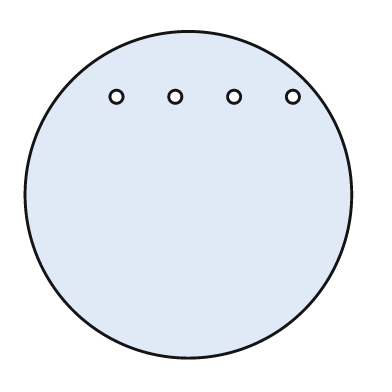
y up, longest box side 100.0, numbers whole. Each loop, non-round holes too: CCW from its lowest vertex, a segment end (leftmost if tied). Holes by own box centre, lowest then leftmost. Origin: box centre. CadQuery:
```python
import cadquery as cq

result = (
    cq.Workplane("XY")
    .moveTo(0.0, 0.0)
    .circle(50.0)
    .moveTo(-22.0, 30.0)
    .circle(2.0)
    .moveTo(-4.0, 30.0)
    .circle(2.0)
    .moveTo(14.0, 30.0)
    .circle(2.0)
    .moveTo(32.0, 30.0)
    .circle(2.0)
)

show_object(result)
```